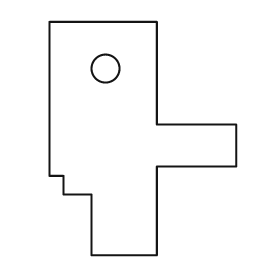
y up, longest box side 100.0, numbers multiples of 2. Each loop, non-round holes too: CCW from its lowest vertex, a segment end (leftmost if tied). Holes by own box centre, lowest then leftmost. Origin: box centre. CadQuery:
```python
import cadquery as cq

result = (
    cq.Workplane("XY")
    .moveTo(-22.0, -50.0)
    .lineTo(6.0, -50.0)
    .lineTo(6.0, -12.0)
    .lineTo(40.0, -12.0)
    .lineTo(40.0, 6.0)
    .lineTo(6.0, 6.0)
    .lineTo(6.0, 50.0)
    .lineTo(-40.0, 50.0)
    .lineTo(-40.0, -16.0)
    .lineTo(-34.0, -16.0)
    .lineTo(-34.0, -24.0)
    .lineTo(-22.0, -24.0)
    .close()
    .moveTo(-16.0, 30.0)
    .circle(6.0)
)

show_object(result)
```